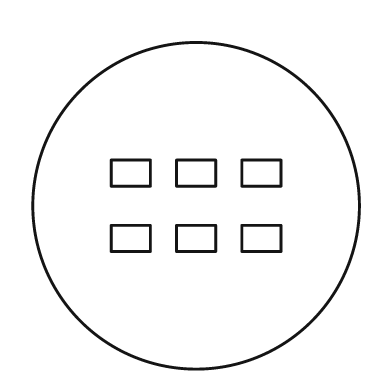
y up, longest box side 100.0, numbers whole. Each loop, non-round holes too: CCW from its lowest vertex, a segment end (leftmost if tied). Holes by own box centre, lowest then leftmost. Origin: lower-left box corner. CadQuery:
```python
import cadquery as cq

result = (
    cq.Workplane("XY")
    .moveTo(50.0, 50.0)
    .circle(50.0)
    .moveTo(24.0, 36.0)
    .lineTo(36.0, 36.0)
    .lineTo(36.0, 44.0)
    .lineTo(24.0, 44.0)
    .close()
    .moveTo(44.0, 36.0)
    .lineTo(56.0, 36.0)
    .lineTo(56.0, 44.0)
    .lineTo(44.0, 44.0)
    .close()
    .moveTo(64.0, 36.0)
    .lineTo(76.0, 36.0)
    .lineTo(76.0, 44.0)
    .lineTo(64.0, 44.0)
    .close()
    .moveTo(24.0, 56.0)
    .lineTo(36.0, 56.0)
    .lineTo(36.0, 64.0)
    .lineTo(24.0, 64.0)
    .close()
    .moveTo(44.0, 56.0)
    .lineTo(56.0, 56.0)
    .lineTo(56.0, 64.0)
    .lineTo(44.0, 64.0)
    .close()
    .moveTo(64.0, 56.0)
    .lineTo(76.0, 56.0)
    .lineTo(76.0, 64.0)
    .lineTo(64.0, 64.0)
    .close()
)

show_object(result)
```